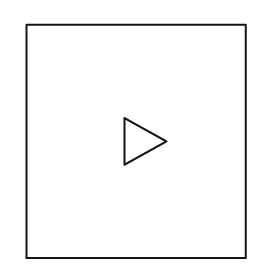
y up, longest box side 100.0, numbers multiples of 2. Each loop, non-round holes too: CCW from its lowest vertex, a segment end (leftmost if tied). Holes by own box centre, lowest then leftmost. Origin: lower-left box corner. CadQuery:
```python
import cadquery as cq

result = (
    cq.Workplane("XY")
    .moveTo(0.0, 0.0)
    .lineTo(94.0, 0.0)
    .lineTo(94.0, 100.0)
    .lineTo(0.0, 100.0)
    .close()
    .moveTo(42.0, 40.0)
    .lineTo(60.0, 50.0)
    .lineTo(42.0, 60.0)
    .close()
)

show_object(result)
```